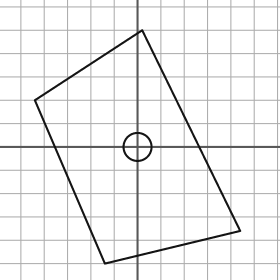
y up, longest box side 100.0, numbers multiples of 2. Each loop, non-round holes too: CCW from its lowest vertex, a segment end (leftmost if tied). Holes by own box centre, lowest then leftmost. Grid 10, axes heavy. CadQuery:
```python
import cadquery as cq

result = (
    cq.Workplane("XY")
    .moveTo(-14.0, -50.0)
    .lineTo(44.0, -36.0)
    .lineTo(2.0, 50.0)
    .lineTo(-44.0, 20.0)
    .close()
    .moveTo(0.0, 0.0)
    .circle(6.0)
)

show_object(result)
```